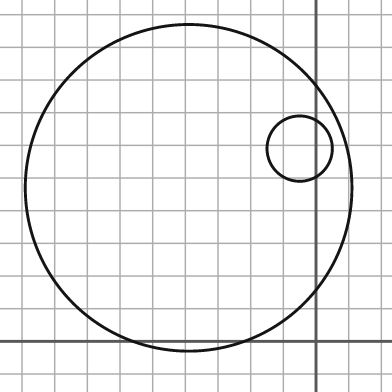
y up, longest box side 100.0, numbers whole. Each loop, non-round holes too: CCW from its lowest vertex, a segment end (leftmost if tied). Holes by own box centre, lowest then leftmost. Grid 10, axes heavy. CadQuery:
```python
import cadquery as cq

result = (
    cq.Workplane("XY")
    .moveTo(-39.0, 47.0)
    .circle(50.0)
    .moveTo(-5.0, 59.0)
    .circle(10.0)
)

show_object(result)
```